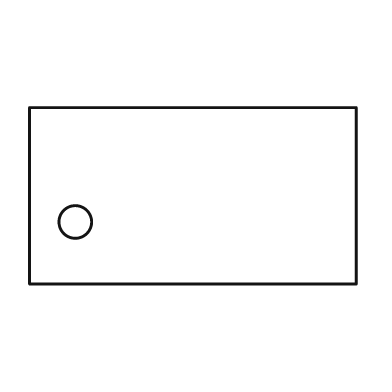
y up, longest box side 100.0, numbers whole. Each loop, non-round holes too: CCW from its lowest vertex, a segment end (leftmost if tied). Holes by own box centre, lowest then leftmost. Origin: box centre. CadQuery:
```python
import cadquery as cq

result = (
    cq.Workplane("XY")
    .moveTo(-50.0, -27.0)
    .lineTo(50.0, -27.0)
    .lineTo(50.0, 27.0)
    .lineTo(-50.0, 27.0)
    .close()
    .moveTo(-36.0, -8.0)
    .circle(5.0)
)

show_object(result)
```